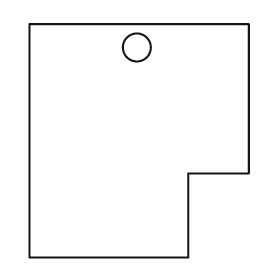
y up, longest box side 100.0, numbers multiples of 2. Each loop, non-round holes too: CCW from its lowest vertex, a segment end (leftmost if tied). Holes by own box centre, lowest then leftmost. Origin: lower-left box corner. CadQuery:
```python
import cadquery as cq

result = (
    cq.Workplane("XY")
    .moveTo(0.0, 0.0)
    .lineTo(68.0, 0.0)
    .lineTo(68.0, 36.0)
    .lineTo(94.0, 36.0)
    .lineTo(94.0, 100.0)
    .lineTo(0.0, 100.0)
    .close()
    .moveTo(46.0, 90.0)
    .circle(6.0)
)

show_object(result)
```